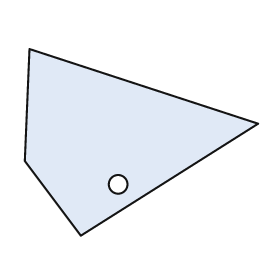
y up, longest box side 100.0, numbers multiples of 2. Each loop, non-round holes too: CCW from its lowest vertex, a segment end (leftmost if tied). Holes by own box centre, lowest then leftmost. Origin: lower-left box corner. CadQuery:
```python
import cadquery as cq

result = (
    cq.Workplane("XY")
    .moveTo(24.0, 0.0)
    .lineTo(100.0, 48.0)
    .lineTo(2.0, 80.0)
    .lineTo(0.0, 32.0)
    .close()
    .moveTo(40.0, 22.0)
    .circle(4.0)
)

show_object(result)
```